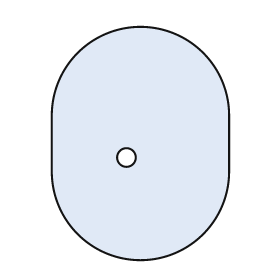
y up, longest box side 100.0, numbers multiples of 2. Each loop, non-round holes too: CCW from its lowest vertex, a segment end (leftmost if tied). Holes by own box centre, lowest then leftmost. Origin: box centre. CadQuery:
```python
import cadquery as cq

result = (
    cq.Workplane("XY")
    .moveTo(-38.0, -12.0)
    .threePointArc((0.0, -50.0), (38.0, -12.0))
    .lineTo(38.0, 12.0)
    .threePointArc((0.0, 50.0), (-38.0, 12.0))
    .close()
    .moveTo(-6.0, -6.0)
    .circle(4.0)
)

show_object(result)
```